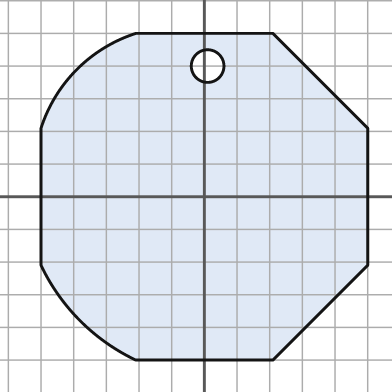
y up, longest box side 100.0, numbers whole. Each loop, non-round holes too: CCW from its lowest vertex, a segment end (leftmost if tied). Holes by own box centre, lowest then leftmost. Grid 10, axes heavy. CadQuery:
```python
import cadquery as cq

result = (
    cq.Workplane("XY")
    .moveTo(-21.0, -50.0)
    .lineTo(21.0, -50.0)
    .lineTo(50.0, -21.0)
    .lineTo(50.0, 21.0)
    .lineTo(21.0, 50.0)
    .lineTo(-21.0, 50.0)
    .threePointArc((-39.0, 39.0), (-50.0, 21.0))
    .lineTo(-50.0, -21.0)
    .threePointArc((-38.0, -38.0), (-21.0, -50.0))
    .close()
    .moveTo(1.0, 40.0)
    .circle(5.0)
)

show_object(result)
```